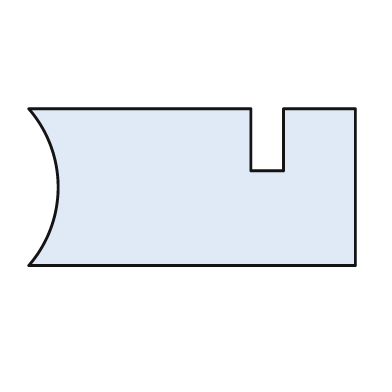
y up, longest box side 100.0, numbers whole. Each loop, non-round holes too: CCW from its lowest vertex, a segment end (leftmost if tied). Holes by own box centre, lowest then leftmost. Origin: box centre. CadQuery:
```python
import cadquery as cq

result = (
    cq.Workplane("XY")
    .moveTo(-50.0, -24.0)
    .lineTo(50.0, -24.0)
    .lineTo(50.0, 24.0)
    .lineTo(28.0, 24.0)
    .lineTo(28.0, 5.0)
    .lineTo(18.0, 5.0)
    .lineTo(18.0, 24.0)
    .lineTo(-50.0, 24.0)
    .threePointArc((-41.0, 0.0), (-50.0, -24.0))
    .close()
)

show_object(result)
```